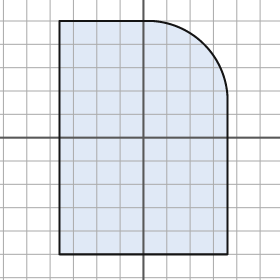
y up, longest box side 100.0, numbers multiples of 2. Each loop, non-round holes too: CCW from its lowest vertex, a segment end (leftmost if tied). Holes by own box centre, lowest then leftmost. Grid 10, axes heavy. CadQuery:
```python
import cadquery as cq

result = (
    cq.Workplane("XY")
    .moveTo(-36.0, -50.0)
    .lineTo(36.0, -50.0)
    .lineTo(36.0, 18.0)
    .threePointArc((26.0, 40.0), (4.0, 50.0))
    .lineTo(-36.0, 50.0)
    .close()
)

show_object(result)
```